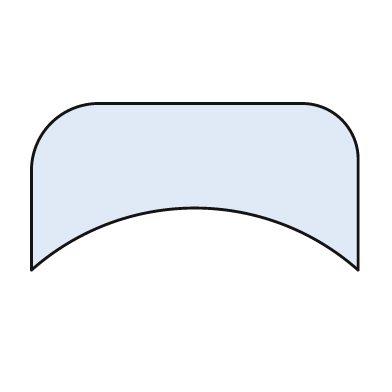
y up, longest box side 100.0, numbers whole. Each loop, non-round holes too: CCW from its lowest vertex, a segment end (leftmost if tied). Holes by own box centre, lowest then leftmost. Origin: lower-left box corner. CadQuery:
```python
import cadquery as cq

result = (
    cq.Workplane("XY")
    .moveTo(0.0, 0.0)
    .threePointArc((50.0, 19.0), (100.0, 0.0))
    .lineTo(100.0, 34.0)
    .threePointArc((95.0, 46.0), (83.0, 51.0))
    .lineTo(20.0, 51.0)
    .threePointArc((6.0, 45.0), (0.0, 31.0))
    .close()
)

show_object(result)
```